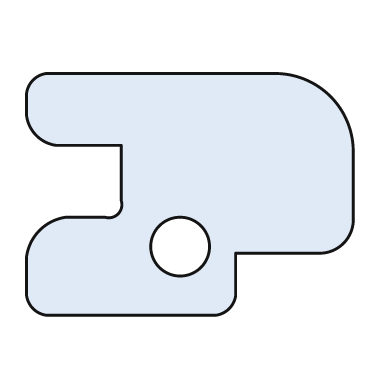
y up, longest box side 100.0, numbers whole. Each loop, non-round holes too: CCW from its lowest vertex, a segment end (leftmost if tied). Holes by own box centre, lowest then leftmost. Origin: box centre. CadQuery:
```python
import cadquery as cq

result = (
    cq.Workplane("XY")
    .moveTo(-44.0, -37.0)
    .lineTo(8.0, -37.0)
    .threePointArc((12.0, -35.0), (14.0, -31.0))
    .lineTo(14.0, -18.0)
    .lineTo(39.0, -18.0)
    .threePointArc((47.0, -15.0), (50.0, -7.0))
    .lineTo(50.0, 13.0)
    .threePointArc((43.0, 30.0), (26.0, 37.0))
    .lineTo(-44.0, 37.0)
    .threePointArc((-48.0, 35.0), (-50.0, 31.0))
    .lineTo(-50.0, 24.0)
    .threePointArc((-47.0, 18.0), (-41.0, 15.0))
    .lineTo(-21.0, 15.0)
    .lineTo(-21.0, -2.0)
    .threePointArc((-22.0, -6.0), (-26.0, -7.0))
    .lineTo(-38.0, -7.0)
    .threePointArc((-46.0, -11.0), (-50.0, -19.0))
    .lineTo(-50.0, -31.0)
    .threePointArc((-48.0, -35.0), (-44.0, -37.0))
    .close()
    .moveTo(-3.0, -16.0)
    .circle(9.0)
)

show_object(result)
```